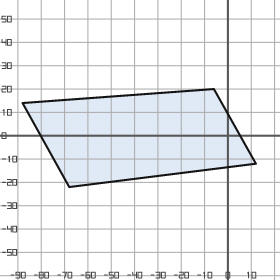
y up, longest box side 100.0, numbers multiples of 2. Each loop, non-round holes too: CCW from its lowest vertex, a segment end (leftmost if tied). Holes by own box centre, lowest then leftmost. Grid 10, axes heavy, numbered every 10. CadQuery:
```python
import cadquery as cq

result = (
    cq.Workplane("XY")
    .moveTo(-68.0, -22.0)
    .lineTo(12.0, -12.0)
    .lineTo(-6.0, 20.0)
    .lineTo(-88.0, 14.0)
    .close()
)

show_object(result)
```